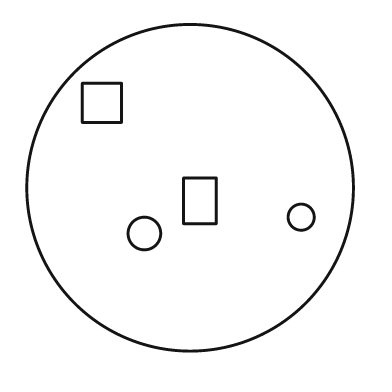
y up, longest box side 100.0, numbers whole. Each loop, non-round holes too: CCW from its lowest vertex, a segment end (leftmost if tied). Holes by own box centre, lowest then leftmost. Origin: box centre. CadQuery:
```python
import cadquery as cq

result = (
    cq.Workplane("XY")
    .moveTo(0.0, 0.0)
    .circle(50.0)
    .moveTo(-14.0, -14.0)
    .circle(5.0)
    .moveTo(34.0, -9.0)
    .circle(4.0)
    .moveTo(-2.0, -11.0)
    .lineTo(8.0, -11.0)
    .lineTo(8.0, 3.0)
    .lineTo(-2.0, 3.0)
    .close()
    .moveTo(-33.0, 20.0)
    .lineTo(-21.0, 20.0)
    .lineTo(-21.0, 32.0)
    .lineTo(-33.0, 32.0)
    .close()
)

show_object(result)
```